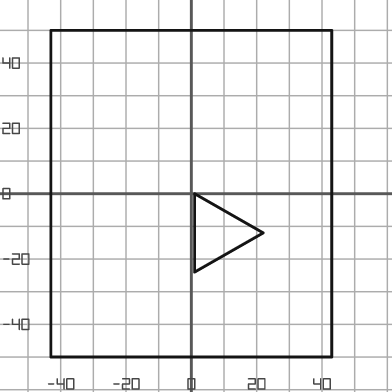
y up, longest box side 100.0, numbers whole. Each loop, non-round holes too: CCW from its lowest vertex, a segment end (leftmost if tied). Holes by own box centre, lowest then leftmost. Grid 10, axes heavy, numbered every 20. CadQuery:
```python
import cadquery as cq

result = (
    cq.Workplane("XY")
    .moveTo(-43.0, -50.0)
    .lineTo(43.0, -50.0)
    .lineTo(43.0, 50.0)
    .lineTo(-43.0, 50.0)
    .close()
    .moveTo(1.0, -24.0)
    .lineTo(22.0, -12.0)
    .lineTo(1.0, 0.0)
    .close()
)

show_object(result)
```